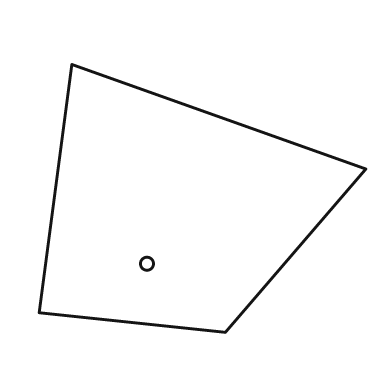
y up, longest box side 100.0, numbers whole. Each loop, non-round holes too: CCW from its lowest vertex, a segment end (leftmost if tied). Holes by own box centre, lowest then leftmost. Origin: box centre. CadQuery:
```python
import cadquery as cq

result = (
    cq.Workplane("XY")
    .moveTo(7.0, -41.0)
    .lineTo(50.0, 9.0)
    .lineTo(-40.0, 41.0)
    .lineTo(-50.0, -35.0)
    .close()
    .moveTo(-17.0, -20.0)
    .circle(2.0)
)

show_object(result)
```